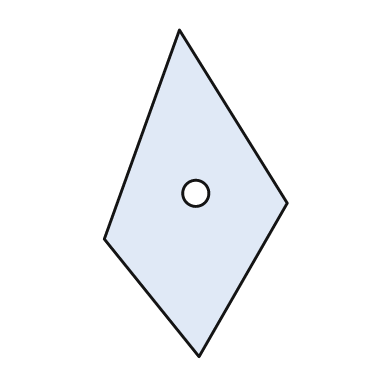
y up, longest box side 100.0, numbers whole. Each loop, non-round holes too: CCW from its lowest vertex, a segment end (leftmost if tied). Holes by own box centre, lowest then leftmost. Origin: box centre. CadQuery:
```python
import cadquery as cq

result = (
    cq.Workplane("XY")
    .moveTo(1.0, -50.0)
    .lineTo(28.0, -3.0)
    .lineTo(-5.0, 50.0)
    .lineTo(-28.0, -14.0)
    .close()
    .moveTo(0.0, 0.0)
    .circle(4.0)
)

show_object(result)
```